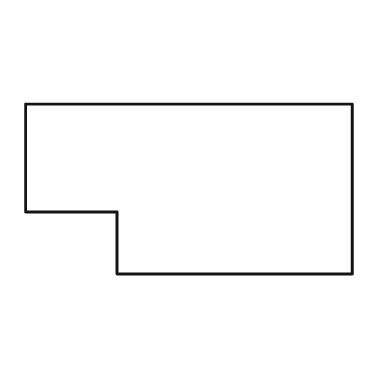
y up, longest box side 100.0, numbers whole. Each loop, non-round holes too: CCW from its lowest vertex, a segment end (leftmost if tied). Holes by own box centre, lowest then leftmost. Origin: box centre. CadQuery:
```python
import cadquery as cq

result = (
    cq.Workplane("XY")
    .moveTo(-22.0, -26.0)
    .lineTo(50.0, -26.0)
    .lineTo(50.0, 26.0)
    .lineTo(-50.0, 26.0)
    .lineTo(-50.0, -7.0)
    .lineTo(-22.0, -7.0)
    .close()
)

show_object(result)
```